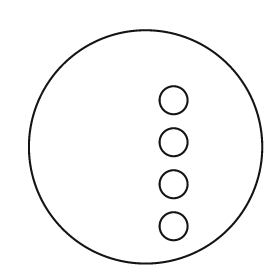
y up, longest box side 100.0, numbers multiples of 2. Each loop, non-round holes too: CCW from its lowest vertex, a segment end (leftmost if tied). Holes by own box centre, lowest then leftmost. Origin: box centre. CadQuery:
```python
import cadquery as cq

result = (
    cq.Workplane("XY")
    .moveTo(0.0, 0.0)
    .circle(50.0)
    .moveTo(12.0, -34.0)
    .circle(6.0)
    .moveTo(12.0, -16.0)
    .circle(6.0)
    .moveTo(12.0, 2.0)
    .circle(6.0)
    .moveTo(12.0, 20.0)
    .circle(6.0)
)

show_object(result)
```